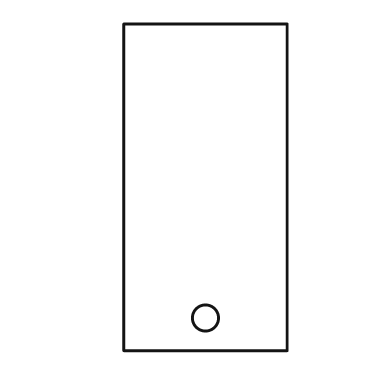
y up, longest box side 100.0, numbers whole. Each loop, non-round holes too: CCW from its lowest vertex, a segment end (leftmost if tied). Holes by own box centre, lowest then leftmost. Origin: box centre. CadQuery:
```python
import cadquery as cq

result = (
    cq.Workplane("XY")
    .moveTo(-25.0, -50.0)
    .lineTo(25.0, -50.0)
    .lineTo(25.0, 50.0)
    .lineTo(-25.0, 50.0)
    .close()
    .moveTo(0.0, -40.0)
    .circle(4.0)
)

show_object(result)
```